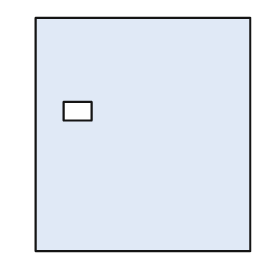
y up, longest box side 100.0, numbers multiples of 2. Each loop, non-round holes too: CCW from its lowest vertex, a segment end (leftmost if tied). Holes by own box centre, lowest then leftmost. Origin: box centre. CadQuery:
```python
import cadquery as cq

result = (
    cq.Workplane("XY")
    .moveTo(-46.0, -50.0)
    .lineTo(46.0, -50.0)
    .lineTo(46.0, 50.0)
    .lineTo(-46.0, 50.0)
    .close()
    .moveTo(-34.0, 6.0)
    .lineTo(-22.0, 6.0)
    .lineTo(-22.0, 14.0)
    .lineTo(-34.0, 14.0)
    .close()
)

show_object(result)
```